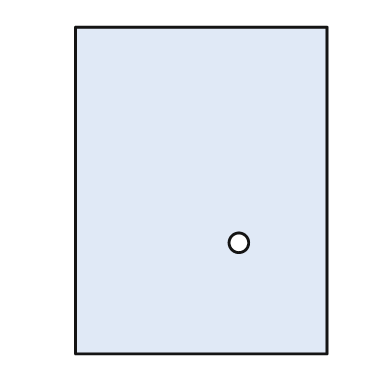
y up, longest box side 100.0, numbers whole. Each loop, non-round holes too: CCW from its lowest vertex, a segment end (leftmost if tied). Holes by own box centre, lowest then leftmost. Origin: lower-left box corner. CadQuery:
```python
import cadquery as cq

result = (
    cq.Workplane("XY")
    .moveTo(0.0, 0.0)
    .lineTo(77.0, 0.0)
    .lineTo(77.0, 100.0)
    .lineTo(0.0, 100.0)
    .close()
    .moveTo(50.0, 34.0)
    .circle(3.0)
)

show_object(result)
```